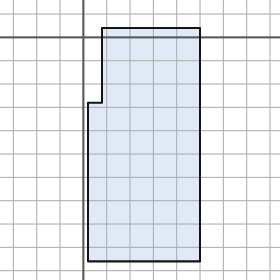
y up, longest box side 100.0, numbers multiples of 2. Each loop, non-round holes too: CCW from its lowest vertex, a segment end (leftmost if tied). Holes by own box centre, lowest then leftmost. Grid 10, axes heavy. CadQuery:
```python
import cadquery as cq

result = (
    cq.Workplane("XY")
    .moveTo(2.0, -96.0)
    .lineTo(50.0, -96.0)
    .lineTo(50.0, 4.0)
    .lineTo(8.0, 4.0)
    .lineTo(8.0, -28.0)
    .lineTo(2.0, -28.0)
    .close()
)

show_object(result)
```